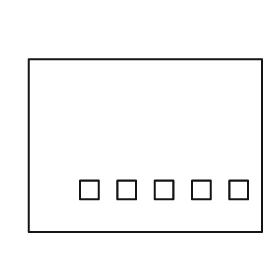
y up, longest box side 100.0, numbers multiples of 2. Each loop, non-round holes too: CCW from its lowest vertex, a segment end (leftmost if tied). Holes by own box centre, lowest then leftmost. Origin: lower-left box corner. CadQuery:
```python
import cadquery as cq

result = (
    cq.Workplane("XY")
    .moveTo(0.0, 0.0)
    .lineTo(100.0, 0.0)
    .lineTo(100.0, 74.0)
    .lineTo(0.0, 74.0)
    .close()
    .moveTo(22.0, 14.0)
    .lineTo(30.0, 14.0)
    .lineTo(30.0, 22.0)
    .lineTo(22.0, 22.0)
    .close()
    .moveTo(38.0, 14.0)
    .lineTo(46.0, 14.0)
    .lineTo(46.0, 22.0)
    .lineTo(38.0, 22.0)
    .close()
    .moveTo(54.0, 14.0)
    .lineTo(62.0, 14.0)
    .lineTo(62.0, 22.0)
    .lineTo(54.0, 22.0)
    .close()
    .moveTo(70.0, 14.0)
    .lineTo(78.0, 14.0)
    .lineTo(78.0, 22.0)
    .lineTo(70.0, 22.0)
    .close()
    .moveTo(86.0, 14.0)
    .lineTo(94.0, 14.0)
    .lineTo(94.0, 22.0)
    .lineTo(86.0, 22.0)
    .close()
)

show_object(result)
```